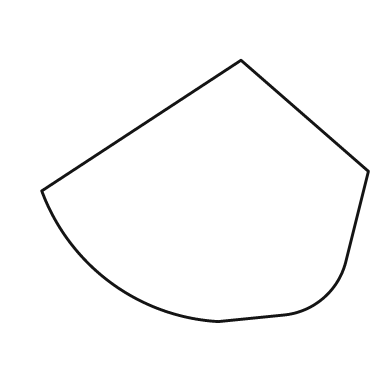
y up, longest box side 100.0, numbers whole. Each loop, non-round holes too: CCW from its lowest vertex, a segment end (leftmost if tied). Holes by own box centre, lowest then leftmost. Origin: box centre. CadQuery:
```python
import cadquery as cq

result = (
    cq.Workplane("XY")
    .moveTo(4.0, -40.0)
    .lineTo(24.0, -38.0)
    .threePointArc((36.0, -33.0), (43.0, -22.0))
    .lineTo(50.0, 6.0)
    .lineTo(11.0, 40.0)
    .lineTo(-50.0, 0.0)
    .threePointArc((-29.0, -28.0), (4.0, -40.0))
    .close()
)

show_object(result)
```